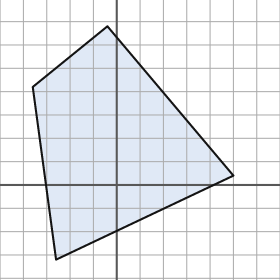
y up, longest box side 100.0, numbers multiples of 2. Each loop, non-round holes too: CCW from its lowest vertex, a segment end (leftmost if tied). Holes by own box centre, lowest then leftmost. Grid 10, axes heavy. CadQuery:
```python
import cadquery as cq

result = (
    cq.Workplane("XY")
    .moveTo(-26.0, -32.0)
    .lineTo(50.0, 4.0)
    .lineTo(-4.0, 68.0)
    .lineTo(-36.0, 42.0)
    .close()
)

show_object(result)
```